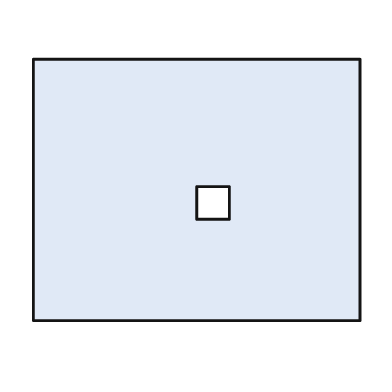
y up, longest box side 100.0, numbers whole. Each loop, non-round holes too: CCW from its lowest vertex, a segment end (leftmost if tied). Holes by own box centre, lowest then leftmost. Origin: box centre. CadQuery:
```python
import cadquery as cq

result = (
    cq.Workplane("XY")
    .moveTo(-50.0, -40.0)
    .lineTo(50.0, -40.0)
    .lineTo(50.0, 40.0)
    .lineTo(-50.0, 40.0)
    .close()
    .moveTo(0.0, -9.0)
    .lineTo(10.0, -9.0)
    .lineTo(10.0, 1.0)
    .lineTo(0.0, 1.0)
    .close()
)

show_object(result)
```